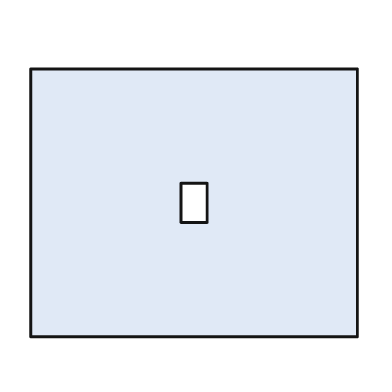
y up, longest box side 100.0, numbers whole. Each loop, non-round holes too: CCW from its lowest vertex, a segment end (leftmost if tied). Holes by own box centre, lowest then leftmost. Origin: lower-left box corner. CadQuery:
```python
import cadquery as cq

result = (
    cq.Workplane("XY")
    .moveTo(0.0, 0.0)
    .lineTo(100.0, 0.0)
    .lineTo(100.0, 82.0)
    .lineTo(0.0, 82.0)
    .close()
    .moveTo(46.0, 35.0)
    .lineTo(54.0, 35.0)
    .lineTo(54.0, 47.0)
    .lineTo(46.0, 47.0)
    .close()
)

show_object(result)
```